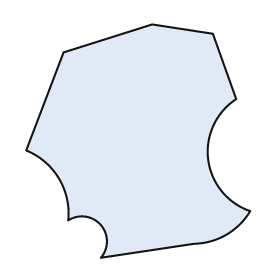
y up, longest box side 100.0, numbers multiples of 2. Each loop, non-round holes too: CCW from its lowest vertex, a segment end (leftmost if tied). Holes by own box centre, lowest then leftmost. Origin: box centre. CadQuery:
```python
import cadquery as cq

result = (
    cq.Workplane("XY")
    .moveTo(-16.0, -50.0)
    .lineTo(24.0, -44.0)
    .threePointArc((38.0, -40.0), (48.0, -30.0))
    .threePointArc((30.0, -8.0), (42.0, 18.0))
    .lineTo(32.0, 46.0)
    .lineTo(6.0, 50.0)
    .lineTo(-32.0, 38.0)
    .lineTo(-48.0, -4.0)
    .threePointArc((-34.0, -16.0), (-30.0, -34.0))
    .threePointArc((-16.0, -36.0), (-16.0, -50.0))
    .close()
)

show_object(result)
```